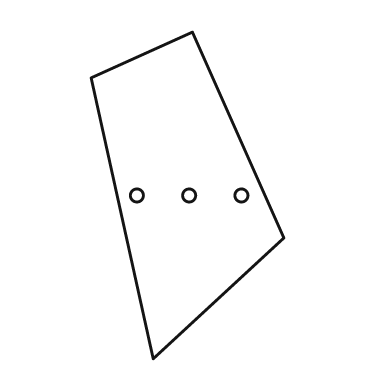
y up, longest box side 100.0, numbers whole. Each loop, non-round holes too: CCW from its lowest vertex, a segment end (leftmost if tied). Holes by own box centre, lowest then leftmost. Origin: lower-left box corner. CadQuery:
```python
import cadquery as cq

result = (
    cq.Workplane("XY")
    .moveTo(19.0, 0.0)
    .lineTo(59.0, 37.0)
    .lineTo(31.0, 100.0)
    .lineTo(0.0, 86.0)
    .close()
    .moveTo(14.0, 50.0)
    .circle(2.0)
    .moveTo(30.0, 50.0)
    .circle(2.0)
    .moveTo(46.0, 50.0)
    .circle(2.0)
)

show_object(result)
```